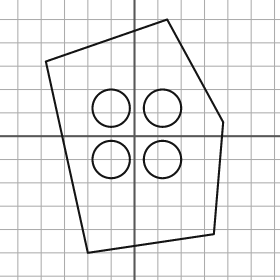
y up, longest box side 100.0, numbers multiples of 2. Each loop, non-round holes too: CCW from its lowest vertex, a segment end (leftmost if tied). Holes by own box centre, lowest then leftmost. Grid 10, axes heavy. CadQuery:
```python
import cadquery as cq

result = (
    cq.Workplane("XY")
    .moveTo(-20.0, -50.0)
    .lineTo(34.0, -42.0)
    .lineTo(38.0, 6.0)
    .lineTo(14.0, 50.0)
    .lineTo(-38.0, 32.0)
    .close()
    .moveTo(-10.0, -10.0)
    .circle(8.0)
    .moveTo(12.0, -10.0)
    .circle(8.0)
    .moveTo(-10.0, 12.0)
    .circle(8.0)
    .moveTo(12.0, 12.0)
    .circle(8.0)
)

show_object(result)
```